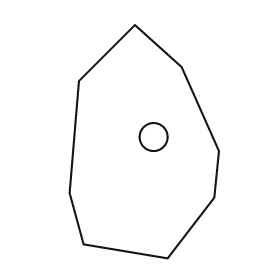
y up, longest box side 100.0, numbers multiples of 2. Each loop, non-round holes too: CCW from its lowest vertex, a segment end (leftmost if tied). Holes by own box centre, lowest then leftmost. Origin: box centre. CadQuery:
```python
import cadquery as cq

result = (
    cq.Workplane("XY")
    .moveTo(10.0, -50.0)
    .lineTo(30.0, -24.0)
    .lineTo(32.0, -4.0)
    .lineTo(16.0, 32.0)
    .lineTo(-4.0, 50.0)
    .lineTo(-28.0, 26.0)
    .lineTo(-32.0, -22.0)
    .lineTo(-26.0, -44.0)
    .close()
    .moveTo(4.0, 2.0)
    .circle(6.0)
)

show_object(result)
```